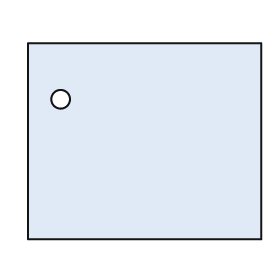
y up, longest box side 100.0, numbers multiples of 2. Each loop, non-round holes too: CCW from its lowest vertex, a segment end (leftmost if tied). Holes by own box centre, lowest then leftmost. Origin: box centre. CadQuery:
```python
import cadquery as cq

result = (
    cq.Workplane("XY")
    .moveTo(-50.0, -42.0)
    .lineTo(50.0, -42.0)
    .lineTo(50.0, 42.0)
    .lineTo(-50.0, 42.0)
    .close()
    .moveTo(-36.0, 18.0)
    .circle(4.0)
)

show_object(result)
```